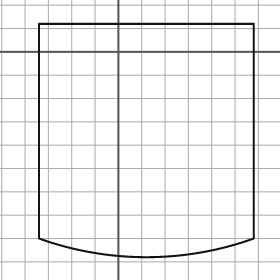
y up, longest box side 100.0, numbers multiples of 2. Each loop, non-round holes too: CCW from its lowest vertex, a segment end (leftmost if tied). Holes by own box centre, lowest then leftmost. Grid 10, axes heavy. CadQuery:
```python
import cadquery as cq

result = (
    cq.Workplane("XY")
    .moveTo(-34.0, -80.0)
    .threePointArc((12.0, -88.0), (58.0, -80.0))
    .lineTo(58.0, 12.0)
    .lineTo(-34.0, 12.0)
    .close()
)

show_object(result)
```